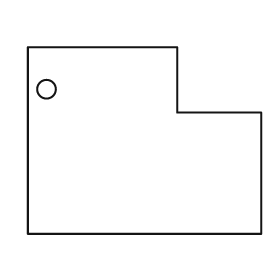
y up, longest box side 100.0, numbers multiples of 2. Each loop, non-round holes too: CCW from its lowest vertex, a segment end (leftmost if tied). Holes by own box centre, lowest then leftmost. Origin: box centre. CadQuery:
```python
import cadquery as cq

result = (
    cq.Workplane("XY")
    .moveTo(-50.0, -40.0)
    .lineTo(50.0, -40.0)
    .lineTo(50.0, 12.0)
    .lineTo(14.0, 12.0)
    .lineTo(14.0, 40.0)
    .lineTo(-50.0, 40.0)
    .close()
    .moveTo(-42.0, 22.0)
    .circle(4.0)
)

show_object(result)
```